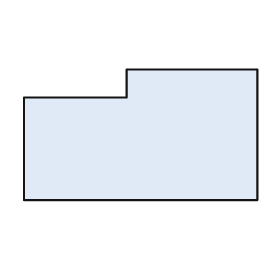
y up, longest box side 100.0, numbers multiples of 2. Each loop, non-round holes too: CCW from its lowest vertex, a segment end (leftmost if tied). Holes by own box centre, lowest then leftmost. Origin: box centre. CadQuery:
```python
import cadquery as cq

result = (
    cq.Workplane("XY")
    .moveTo(-50.0, -28.0)
    .lineTo(50.0, -28.0)
    .lineTo(50.0, 28.0)
    .lineTo(-6.0, 28.0)
    .lineTo(-6.0, 16.0)
    .lineTo(-50.0, 16.0)
    .close()
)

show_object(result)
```